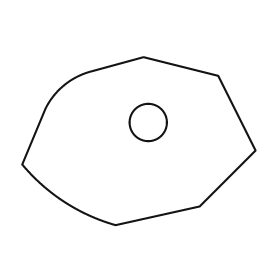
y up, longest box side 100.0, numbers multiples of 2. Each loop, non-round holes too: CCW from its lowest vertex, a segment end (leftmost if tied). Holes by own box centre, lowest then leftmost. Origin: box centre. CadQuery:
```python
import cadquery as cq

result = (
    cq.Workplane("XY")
    .moveTo(-10.0, -36.0)
    .lineTo(26.0, -28.0)
    .lineTo(50.0, -4.0)
    .lineTo(34.0, 28.0)
    .lineTo(2.0, 36.0)
    .lineTo(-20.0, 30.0)
    .threePointArc((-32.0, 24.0), (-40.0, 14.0))
    .lineTo(-50.0, -10.0)
    .threePointArc((-32.0, -26.0), (-10.0, -36.0))
    .close()
    .moveTo(4.0, 8.0)
    .circle(8.0)
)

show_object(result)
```